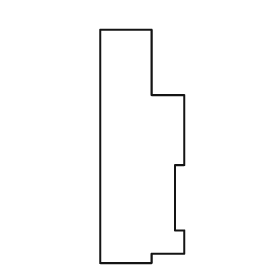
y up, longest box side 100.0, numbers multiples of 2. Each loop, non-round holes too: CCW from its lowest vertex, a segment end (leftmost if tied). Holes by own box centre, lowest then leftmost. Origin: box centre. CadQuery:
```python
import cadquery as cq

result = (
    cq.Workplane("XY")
    .moveTo(-18.0, -50.0)
    .lineTo(4.0, -50.0)
    .lineTo(4.0, -46.0)
    .lineTo(18.0, -46.0)
    .lineTo(18.0, -36.0)
    .lineTo(14.0, -36.0)
    .lineTo(14.0, -8.0)
    .lineTo(18.0, -8.0)
    .lineTo(18.0, 22.0)
    .lineTo(4.0, 22.0)
    .lineTo(4.0, 50.0)
    .lineTo(-18.0, 50.0)
    .close()
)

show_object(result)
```